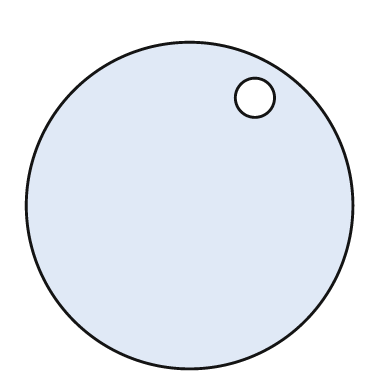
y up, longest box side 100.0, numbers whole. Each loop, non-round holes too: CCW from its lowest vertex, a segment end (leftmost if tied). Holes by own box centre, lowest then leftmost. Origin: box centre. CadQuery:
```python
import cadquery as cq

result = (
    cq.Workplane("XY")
    .moveTo(0.0, 0.0)
    .circle(50.0)
    .moveTo(20.0, 33.0)
    .circle(6.0)
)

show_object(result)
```